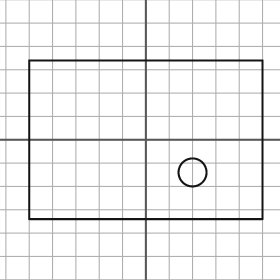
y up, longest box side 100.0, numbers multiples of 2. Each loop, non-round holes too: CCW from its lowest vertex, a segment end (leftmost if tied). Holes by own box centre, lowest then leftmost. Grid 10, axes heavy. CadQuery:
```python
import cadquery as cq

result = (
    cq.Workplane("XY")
    .moveTo(-50.0, -34.0)
    .lineTo(50.0, -34.0)
    .lineTo(50.0, 34.0)
    .lineTo(-50.0, 34.0)
    .close()
    .moveTo(20.0, -14.0)
    .circle(6.0)
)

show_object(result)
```